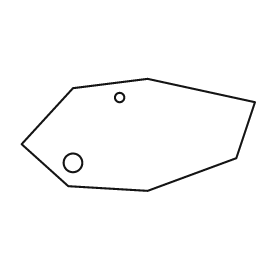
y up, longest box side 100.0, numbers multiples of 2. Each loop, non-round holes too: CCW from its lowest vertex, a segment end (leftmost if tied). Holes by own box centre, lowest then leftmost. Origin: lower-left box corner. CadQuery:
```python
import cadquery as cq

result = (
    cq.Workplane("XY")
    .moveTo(54.0, 0.0)
    .lineTo(92.0, 14.0)
    .lineTo(100.0, 38.0)
    .lineTo(54.0, 48.0)
    .lineTo(22.0, 44.0)
    .lineTo(0.0, 20.0)
    .lineTo(20.0, 2.0)
    .close()
    .moveTo(22.0, 12.0)
    .circle(4.0)
    .moveTo(42.0, 40.0)
    .circle(2.0)
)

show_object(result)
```